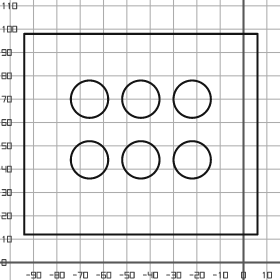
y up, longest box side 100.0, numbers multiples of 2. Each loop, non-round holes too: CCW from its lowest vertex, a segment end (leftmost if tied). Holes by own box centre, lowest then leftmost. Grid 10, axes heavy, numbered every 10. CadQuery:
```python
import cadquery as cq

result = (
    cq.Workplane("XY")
    .moveTo(-94.0, 12.0)
    .lineTo(6.0, 12.0)
    .lineTo(6.0, 98.0)
    .lineTo(-94.0, 98.0)
    .close()
    .moveTo(-66.0, 44.0)
    .circle(8.0)
    .moveTo(-44.0, 44.0)
    .circle(8.0)
    .moveTo(-22.0, 44.0)
    .circle(8.0)
    .moveTo(-66.0, 70.0)
    .circle(8.0)
    .moveTo(-44.0, 70.0)
    .circle(8.0)
    .moveTo(-22.0, 70.0)
    .circle(8.0)
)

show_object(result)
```